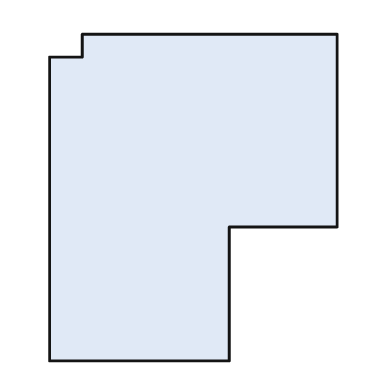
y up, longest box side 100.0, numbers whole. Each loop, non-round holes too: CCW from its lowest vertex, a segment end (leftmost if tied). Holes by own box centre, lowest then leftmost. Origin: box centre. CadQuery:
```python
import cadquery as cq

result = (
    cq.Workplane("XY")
    .moveTo(-44.0, -50.0)
    .lineTo(11.0, -50.0)
    .lineTo(11.0, -9.0)
    .lineTo(44.0, -9.0)
    .lineTo(44.0, 50.0)
    .lineTo(-34.0, 50.0)
    .lineTo(-34.0, 43.0)
    .lineTo(-44.0, 43.0)
    .close()
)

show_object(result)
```